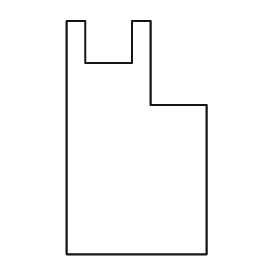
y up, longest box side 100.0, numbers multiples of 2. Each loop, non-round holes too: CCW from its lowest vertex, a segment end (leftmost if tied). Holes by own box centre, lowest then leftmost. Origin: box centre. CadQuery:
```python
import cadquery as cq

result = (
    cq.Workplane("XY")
    .moveTo(-30.0, -50.0)
    .lineTo(30.0, -50.0)
    .lineTo(30.0, 14.0)
    .lineTo(6.0, 14.0)
    .lineTo(6.0, 50.0)
    .lineTo(-2.0, 50.0)
    .lineTo(-2.0, 32.0)
    .lineTo(-22.0, 32.0)
    .lineTo(-22.0, 50.0)
    .lineTo(-30.0, 50.0)
    .close()
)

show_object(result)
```